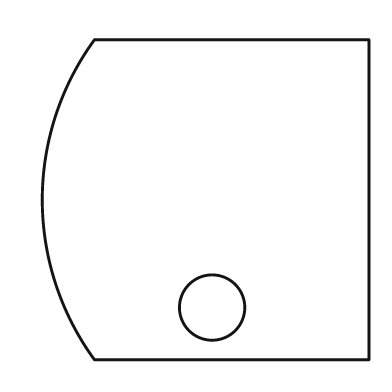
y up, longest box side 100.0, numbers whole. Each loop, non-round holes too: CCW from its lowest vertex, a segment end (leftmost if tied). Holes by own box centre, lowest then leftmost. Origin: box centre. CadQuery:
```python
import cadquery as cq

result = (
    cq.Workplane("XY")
    .moveTo(-34.0, -49.0)
    .lineTo(50.0, -49.0)
    .lineTo(50.0, 49.0)
    .lineTo(-34.0, 49.0)
    .threePointArc((-50.0, 0.0), (-34.0, -49.0))
    .close()
    .moveTo(2.0, -33.0)
    .circle(10.0)
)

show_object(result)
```